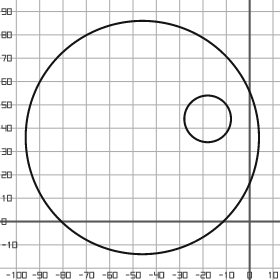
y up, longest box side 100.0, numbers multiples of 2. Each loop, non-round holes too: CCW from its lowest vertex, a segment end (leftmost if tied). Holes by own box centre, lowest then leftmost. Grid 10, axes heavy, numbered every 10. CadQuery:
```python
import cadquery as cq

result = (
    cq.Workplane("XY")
    .moveTo(-46.0, 36.0)
    .circle(50.0)
    .moveTo(-18.0, 44.0)
    .circle(10.0)
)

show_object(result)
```